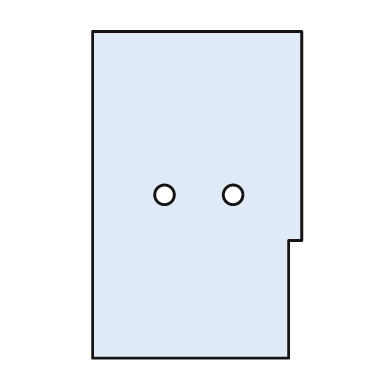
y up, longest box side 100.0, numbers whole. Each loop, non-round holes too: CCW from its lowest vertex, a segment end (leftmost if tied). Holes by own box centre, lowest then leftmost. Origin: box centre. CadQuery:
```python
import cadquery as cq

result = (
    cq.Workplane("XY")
    .moveTo(-32.0, -50.0)
    .lineTo(28.0, -50.0)
    .lineTo(28.0, -14.0)
    .lineTo(32.0, -14.0)
    .lineTo(32.0, 50.0)
    .lineTo(-32.0, 50.0)
    .close()
    .moveTo(-10.0, 0.0)
    .circle(3.0)
    .moveTo(11.0, 0.0)
    .circle(3.0)
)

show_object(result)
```